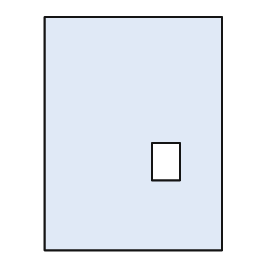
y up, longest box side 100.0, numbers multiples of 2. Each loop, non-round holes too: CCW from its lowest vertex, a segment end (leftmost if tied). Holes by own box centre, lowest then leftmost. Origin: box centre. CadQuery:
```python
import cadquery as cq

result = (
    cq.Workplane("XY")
    .moveTo(-38.0, -50.0)
    .lineTo(38.0, -50.0)
    .lineTo(38.0, 50.0)
    .lineTo(-38.0, 50.0)
    .close()
    .moveTo(8.0, -20.0)
    .lineTo(20.0, -20.0)
    .lineTo(20.0, -4.0)
    .lineTo(8.0, -4.0)
    .close()
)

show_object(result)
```